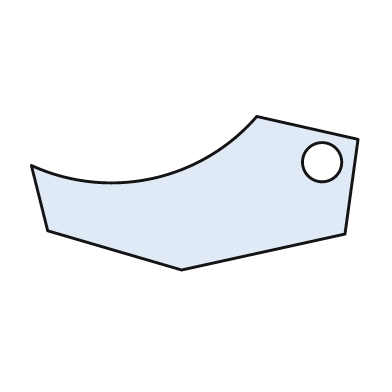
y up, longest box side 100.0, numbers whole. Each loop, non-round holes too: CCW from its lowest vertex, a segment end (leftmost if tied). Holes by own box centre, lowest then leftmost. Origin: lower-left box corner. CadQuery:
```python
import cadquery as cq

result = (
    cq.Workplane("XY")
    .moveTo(46.0, 0.0)
    .lineTo(96.0, 11.0)
    .lineTo(100.0, 40.0)
    .lineTo(69.0, 47.0)
    .threePointArc((37.0, 28.0), (0.0, 32.0))
    .lineTo(5.0, 12.0)
    .close()
    .moveTo(89.0, 33.0)
    .circle(6.0)
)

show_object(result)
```